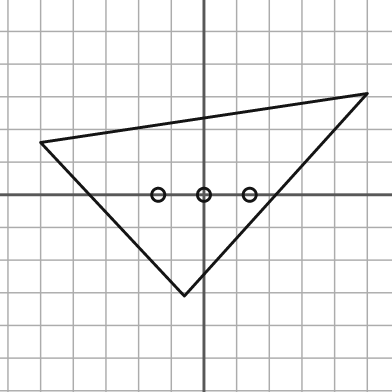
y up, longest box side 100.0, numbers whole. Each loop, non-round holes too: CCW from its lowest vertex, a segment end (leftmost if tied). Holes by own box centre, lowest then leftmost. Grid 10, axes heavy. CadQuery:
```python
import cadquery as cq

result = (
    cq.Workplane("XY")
    .moveTo(-6.0, -31.0)
    .lineTo(50.0, 31.0)
    .lineTo(-50.0, 16.0)
    .close()
    .moveTo(-14.0, 0.0)
    .circle(2.0)
    .moveTo(0.0, 0.0)
    .circle(2.0)
    .moveTo(14.0, 0.0)
    .circle(2.0)
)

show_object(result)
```